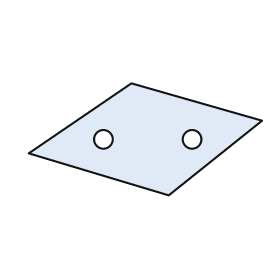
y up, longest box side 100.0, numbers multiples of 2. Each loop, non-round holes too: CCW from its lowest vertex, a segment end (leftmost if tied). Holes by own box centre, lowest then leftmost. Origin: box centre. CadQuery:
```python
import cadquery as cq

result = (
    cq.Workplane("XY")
    .moveTo(10.0, -24.0)
    .lineTo(50.0, 8.0)
    .lineTo(-6.0, 24.0)
    .lineTo(-50.0, -6.0)
    .close()
    .moveTo(-18.0, 0.0)
    .circle(4.0)
    .moveTo(20.0, 0.0)
    .circle(4.0)
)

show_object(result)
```